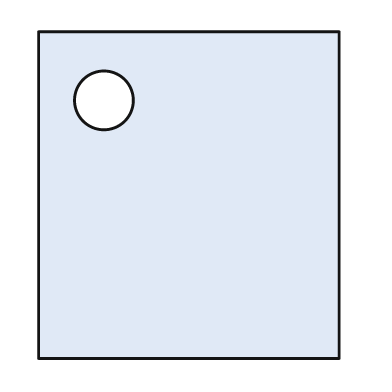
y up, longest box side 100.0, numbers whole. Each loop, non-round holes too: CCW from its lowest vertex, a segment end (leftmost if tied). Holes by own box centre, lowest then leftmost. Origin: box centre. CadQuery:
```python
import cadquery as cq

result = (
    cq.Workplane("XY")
    .moveTo(-46.0, -50.0)
    .lineTo(46.0, -50.0)
    .lineTo(46.0, 50.0)
    .lineTo(-46.0, 50.0)
    .close()
    .moveTo(-26.0, 29.0)
    .circle(9.0)
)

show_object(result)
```